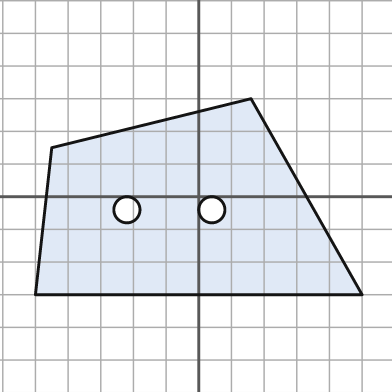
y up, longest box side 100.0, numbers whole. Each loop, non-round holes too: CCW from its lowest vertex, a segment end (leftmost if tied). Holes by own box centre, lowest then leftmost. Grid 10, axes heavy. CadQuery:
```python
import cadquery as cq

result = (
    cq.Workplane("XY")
    .moveTo(-50.0, -30.0)
    .lineTo(50.0, -30.0)
    .lineTo(16.0, 30.0)
    .lineTo(-45.0, 15.0)
    .close()
    .moveTo(-22.0, -4.0)
    .circle(4.0)
    .moveTo(4.0, -4.0)
    .circle(4.0)
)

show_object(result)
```